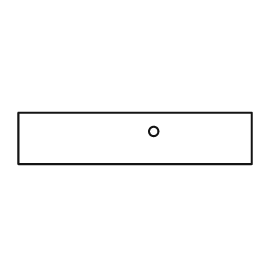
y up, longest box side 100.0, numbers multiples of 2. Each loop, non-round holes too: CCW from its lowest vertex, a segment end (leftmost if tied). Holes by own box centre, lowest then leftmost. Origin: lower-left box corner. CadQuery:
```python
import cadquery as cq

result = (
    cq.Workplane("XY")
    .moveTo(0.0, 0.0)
    .lineTo(100.0, 0.0)
    .lineTo(100.0, 22.0)
    .lineTo(0.0, 22.0)
    .close()
    .moveTo(58.0, 14.0)
    .circle(2.0)
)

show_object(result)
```